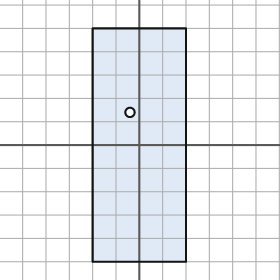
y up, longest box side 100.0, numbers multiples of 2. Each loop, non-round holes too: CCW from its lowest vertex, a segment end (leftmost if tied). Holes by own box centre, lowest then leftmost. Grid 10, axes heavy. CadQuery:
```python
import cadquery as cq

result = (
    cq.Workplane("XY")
    .moveTo(-20.0, -50.0)
    .lineTo(20.0, -50.0)
    .lineTo(20.0, 50.0)
    .lineTo(-20.0, 50.0)
    .close()
    .moveTo(-4.0, 14.0)
    .circle(2.0)
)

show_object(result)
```